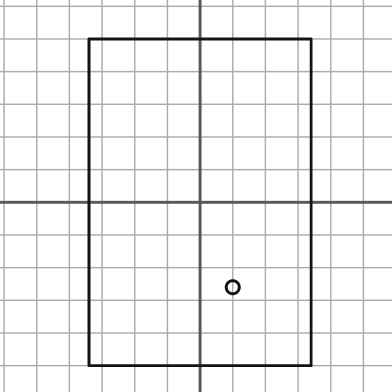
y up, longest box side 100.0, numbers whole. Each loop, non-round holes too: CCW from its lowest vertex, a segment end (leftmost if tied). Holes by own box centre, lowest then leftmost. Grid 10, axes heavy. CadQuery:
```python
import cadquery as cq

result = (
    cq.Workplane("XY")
    .moveTo(-34.0, -50.0)
    .lineTo(34.0, -50.0)
    .lineTo(34.0, 50.0)
    .lineTo(-34.0, 50.0)
    .close()
    .moveTo(10.0, -26.0)
    .circle(2.0)
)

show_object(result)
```